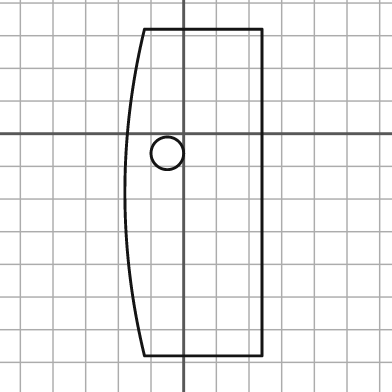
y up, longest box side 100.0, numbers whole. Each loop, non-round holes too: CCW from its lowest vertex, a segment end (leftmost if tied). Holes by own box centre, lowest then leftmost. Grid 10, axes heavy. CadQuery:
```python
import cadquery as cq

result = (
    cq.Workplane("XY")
    .moveTo(-12.0, -68.0)
    .lineTo(24.0, -68.0)
    .lineTo(24.0, 32.0)
    .lineTo(-12.0, 32.0)
    .threePointArc((-18.0, -18.0), (-12.0, -68.0))
    .close()
    .moveTo(-5.0, -6.0)
    .circle(5.0)
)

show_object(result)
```